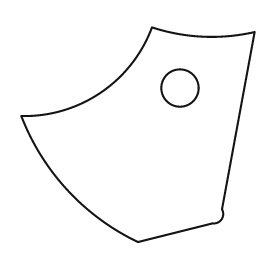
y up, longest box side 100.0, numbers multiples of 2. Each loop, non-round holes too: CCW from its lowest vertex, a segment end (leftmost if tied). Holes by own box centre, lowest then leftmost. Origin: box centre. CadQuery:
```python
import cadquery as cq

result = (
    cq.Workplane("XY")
    .moveTo(0.0, -46.0)
    .lineTo(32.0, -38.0)
    .threePointArc((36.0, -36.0), (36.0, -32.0))
    .lineTo(50.0, 44.0)
    .threePointArc((28.0, 42.0), (6.0, 46.0))
    .threePointArc((-16.0, 18.0), (-50.0, 8.0))
    .threePointArc((-30.0, -24.0), (0.0, -46.0))
    .close()
    .moveTo(18.0, 20.0)
    .circle(8.0)
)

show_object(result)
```